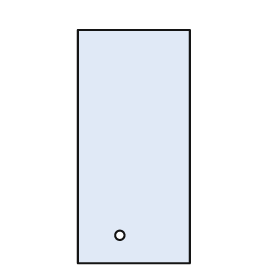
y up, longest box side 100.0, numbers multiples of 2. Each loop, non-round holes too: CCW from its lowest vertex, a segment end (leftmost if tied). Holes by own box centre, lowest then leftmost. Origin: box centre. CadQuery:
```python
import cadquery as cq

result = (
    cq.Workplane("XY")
    .moveTo(-24.0, -50.0)
    .lineTo(24.0, -50.0)
    .lineTo(24.0, 50.0)
    .lineTo(-24.0, 50.0)
    .close()
    .moveTo(-6.0, -38.0)
    .circle(2.0)
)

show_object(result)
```